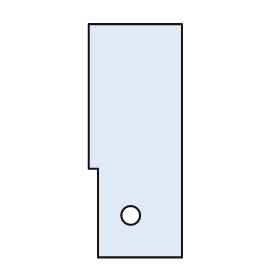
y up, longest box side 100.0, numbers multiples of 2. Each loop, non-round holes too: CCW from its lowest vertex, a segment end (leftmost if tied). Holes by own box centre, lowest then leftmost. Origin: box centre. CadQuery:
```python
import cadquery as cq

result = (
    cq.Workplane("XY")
    .moveTo(-16.0, -50.0)
    .lineTo(20.0, -50.0)
    .lineTo(20.0, 50.0)
    .lineTo(-20.0, 50.0)
    .lineTo(-20.0, -12.0)
    .lineTo(-16.0, -12.0)
    .close()
    .moveTo(-2.0, -32.0)
    .circle(4.0)
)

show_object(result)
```